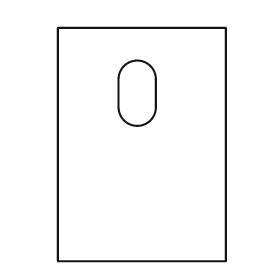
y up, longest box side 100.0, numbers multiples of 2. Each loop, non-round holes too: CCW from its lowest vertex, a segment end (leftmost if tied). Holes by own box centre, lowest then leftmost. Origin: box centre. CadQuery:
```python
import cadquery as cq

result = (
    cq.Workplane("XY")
    .moveTo(-36.0, -50.0)
    .lineTo(36.0, -50.0)
    .lineTo(36.0, 50.0)
    .lineTo(-36.0, 50.0)
    .close()
    .moveTo(-10.0, 16.0)
    .threePointArc((-2.0, 8.0), (6.0, 16.0))
    .lineTo(6.0, 28.0)
    .threePointArc((-2.0, 36.0), (-10.0, 28.0))
    .close()
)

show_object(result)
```